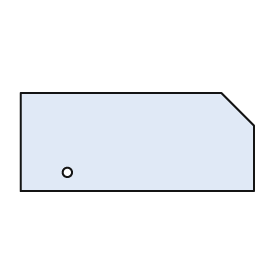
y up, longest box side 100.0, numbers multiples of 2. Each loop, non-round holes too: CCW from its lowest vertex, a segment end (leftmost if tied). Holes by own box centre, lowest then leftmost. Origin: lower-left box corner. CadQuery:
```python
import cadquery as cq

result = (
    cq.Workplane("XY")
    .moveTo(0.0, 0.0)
    .lineTo(100.0, 0.0)
    .lineTo(100.0, 28.0)
    .lineTo(86.0, 42.0)
    .lineTo(0.0, 42.0)
    .close()
    .moveTo(20.0, 8.0)
    .circle(2.0)
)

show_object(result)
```